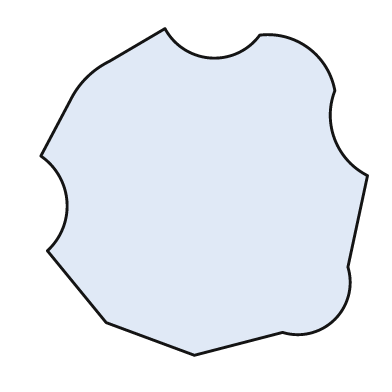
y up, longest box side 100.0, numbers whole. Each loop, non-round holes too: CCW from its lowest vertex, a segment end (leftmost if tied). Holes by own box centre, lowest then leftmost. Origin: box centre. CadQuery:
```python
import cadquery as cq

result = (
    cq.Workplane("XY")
    .moveTo(-3.0, -50.0)
    .lineTo(24.0, -43.0)
    .threePointArc((40.0, -39.0), (44.0, -23.0))
    .lineTo(50.0, 5.0)
    .threePointArc((40.0, 16.0), (40.0, 31.0))
    .threePointArc((32.0, 44.0), (17.0, 48.0))
    .threePointArc((2.0, 41.0), (-12.0, 50.0))
    .lineTo(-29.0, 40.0)
    .threePointArc((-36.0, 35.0), (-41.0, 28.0))
    .lineTo(-50.0, 11.0)
    .threePointArc((-42.0, -3.0), (-48.0, -18.0))
    .lineTo(-30.0, -40.0)
    .close()
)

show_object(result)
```